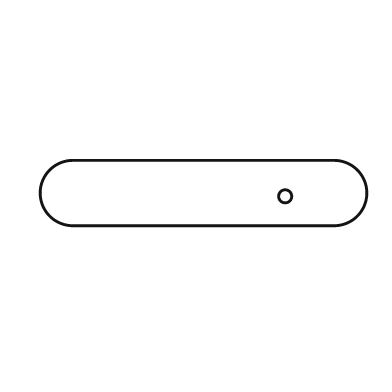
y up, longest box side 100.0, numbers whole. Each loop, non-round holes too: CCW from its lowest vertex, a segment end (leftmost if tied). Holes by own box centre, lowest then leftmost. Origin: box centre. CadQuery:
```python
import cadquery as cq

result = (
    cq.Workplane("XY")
    .moveTo(-40.0, -10.0)
    .lineTo(40.0, -10.0)
    .threePointArc((50.0, 0.0), (40.0, 10.0))
    .lineTo(-40.0, 10.0)
    .threePointArc((-50.0, 0.0), (-40.0, -10.0))
    .close()
    .moveTo(25.0, -1.0)
    .circle(2.0)
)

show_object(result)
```